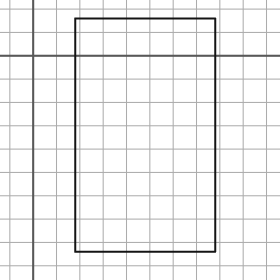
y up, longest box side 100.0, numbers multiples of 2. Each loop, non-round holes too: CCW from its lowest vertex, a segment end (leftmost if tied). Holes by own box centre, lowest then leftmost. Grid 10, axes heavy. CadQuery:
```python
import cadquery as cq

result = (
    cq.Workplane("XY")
    .moveTo(18.0, -84.0)
    .lineTo(78.0, -84.0)
    .lineTo(78.0, 16.0)
    .lineTo(18.0, 16.0)
    .close()
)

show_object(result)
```